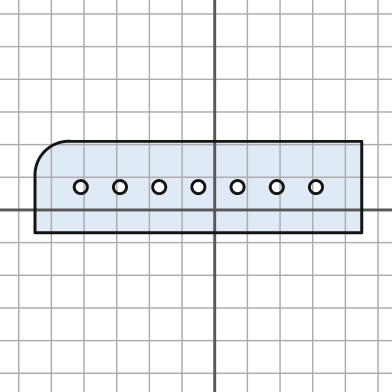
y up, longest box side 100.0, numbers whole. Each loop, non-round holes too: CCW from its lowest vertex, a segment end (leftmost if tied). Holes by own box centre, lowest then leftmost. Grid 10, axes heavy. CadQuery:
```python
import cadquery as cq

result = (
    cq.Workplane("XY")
    .moveTo(-55.0, -7.0)
    .lineTo(45.0, -7.0)
    .lineTo(45.0, 21.0)
    .lineTo(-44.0, 21.0)
    .threePointArc((-52.0, 18.0), (-55.0, 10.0))
    .close()
    .moveTo(-41.0, 7.0)
    .circle(2.0)
    .moveTo(-29.0, 7.0)
    .circle(2.0)
    .moveTo(-17.0, 7.0)
    .circle(2.0)
    .moveTo(-5.0, 7.0)
    .circle(2.0)
    .moveTo(7.0, 7.0)
    .circle(2.0)
    .moveTo(19.0, 7.0)
    .circle(2.0)
    .moveTo(31.0, 7.0)
    .circle(2.0)
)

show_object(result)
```